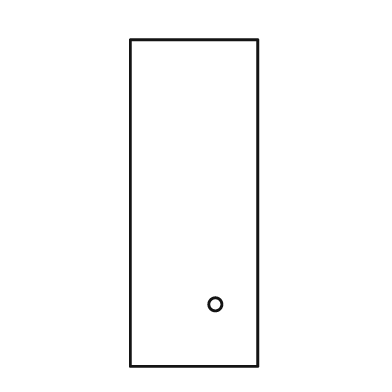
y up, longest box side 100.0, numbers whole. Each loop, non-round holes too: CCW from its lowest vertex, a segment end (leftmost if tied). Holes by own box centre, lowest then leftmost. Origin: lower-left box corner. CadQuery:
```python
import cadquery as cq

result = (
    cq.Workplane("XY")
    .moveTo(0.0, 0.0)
    .lineTo(39.0, 0.0)
    .lineTo(39.0, 100.0)
    .lineTo(0.0, 100.0)
    .close()
    .moveTo(26.0, 19.0)
    .circle(2.0)
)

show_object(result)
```